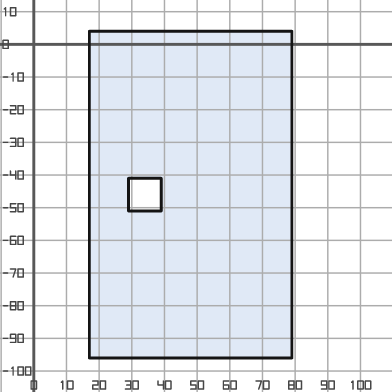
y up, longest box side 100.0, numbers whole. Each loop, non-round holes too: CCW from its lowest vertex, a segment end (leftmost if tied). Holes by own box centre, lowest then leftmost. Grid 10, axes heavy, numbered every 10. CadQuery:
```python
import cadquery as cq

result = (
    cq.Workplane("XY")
    .moveTo(17.0, -96.0)
    .lineTo(79.0, -96.0)
    .lineTo(79.0, 4.0)
    .lineTo(17.0, 4.0)
    .close()
    .moveTo(29.0, -51.0)
    .lineTo(39.0, -51.0)
    .lineTo(39.0, -41.0)
    .lineTo(29.0, -41.0)
    .close()
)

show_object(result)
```